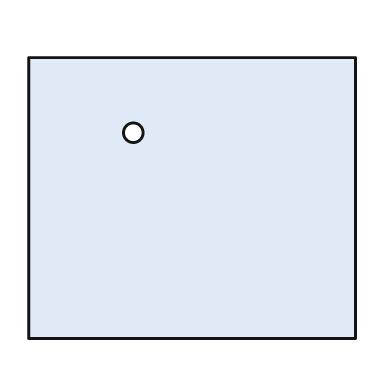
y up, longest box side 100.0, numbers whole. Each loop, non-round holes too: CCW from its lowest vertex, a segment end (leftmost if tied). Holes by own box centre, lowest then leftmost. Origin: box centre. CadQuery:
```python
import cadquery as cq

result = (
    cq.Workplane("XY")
    .moveTo(-50.0, -43.0)
    .lineTo(50.0, -43.0)
    .lineTo(50.0, 43.0)
    .lineTo(-50.0, 43.0)
    .close()
    .moveTo(-18.0, 20.0)
    .circle(3.0)
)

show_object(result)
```